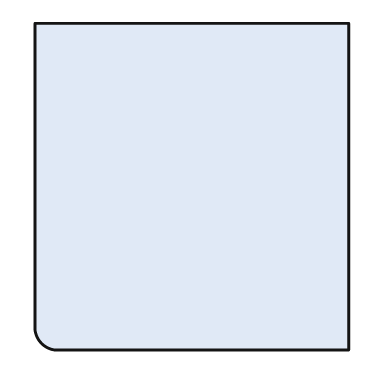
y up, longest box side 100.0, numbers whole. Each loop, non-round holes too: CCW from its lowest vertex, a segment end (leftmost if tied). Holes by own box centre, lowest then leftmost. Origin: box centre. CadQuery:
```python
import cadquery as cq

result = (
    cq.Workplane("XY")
    .moveTo(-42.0, -50.0)
    .lineTo(48.0, -50.0)
    .lineTo(48.0, 50.0)
    .lineTo(-48.0, 50.0)
    .lineTo(-48.0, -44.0)
    .threePointArc((-46.0, -48.0), (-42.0, -50.0))
    .close()
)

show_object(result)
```